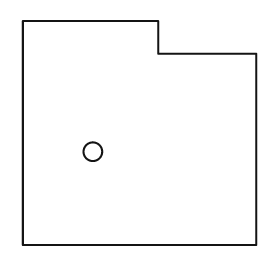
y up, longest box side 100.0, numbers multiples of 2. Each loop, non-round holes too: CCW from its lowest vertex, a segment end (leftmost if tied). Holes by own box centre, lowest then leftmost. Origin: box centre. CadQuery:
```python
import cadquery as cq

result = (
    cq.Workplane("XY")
    .moveTo(-50.0, -48.0)
    .lineTo(50.0, -48.0)
    .lineTo(50.0, 34.0)
    .lineTo(8.0, 34.0)
    .lineTo(8.0, 48.0)
    .lineTo(-50.0, 48.0)
    .close()
    .moveTo(-20.0, -8.0)
    .circle(4.0)
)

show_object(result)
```